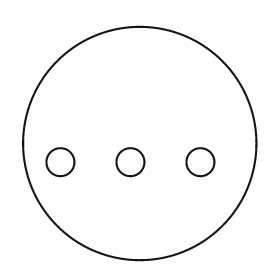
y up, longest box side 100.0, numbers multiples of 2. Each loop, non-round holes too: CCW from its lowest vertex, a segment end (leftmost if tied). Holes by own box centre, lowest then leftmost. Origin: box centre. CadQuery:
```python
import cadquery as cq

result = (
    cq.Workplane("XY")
    .moveTo(0.0, 0.0)
    .circle(50.0)
    .moveTo(-34.0, -8.0)
    .circle(6.0)
    .moveTo(-4.0, -8.0)
    .circle(6.0)
    .moveTo(26.0, -8.0)
    .circle(6.0)
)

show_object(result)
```